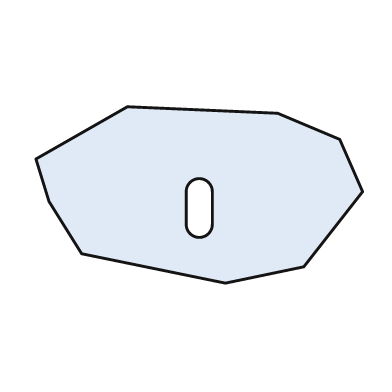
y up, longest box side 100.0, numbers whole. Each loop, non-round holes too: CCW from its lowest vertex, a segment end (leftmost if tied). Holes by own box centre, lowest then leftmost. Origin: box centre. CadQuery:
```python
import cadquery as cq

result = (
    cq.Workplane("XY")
    .moveTo(8.0, -27.0)
    .lineTo(32.0, -22.0)
    .lineTo(50.0, 1.0)
    .lineTo(43.0, 17.0)
    .lineTo(24.0, 25.0)
    .lineTo(-22.0, 27.0)
    .lineTo(-50.0, 11.0)
    .lineTo(-46.0, -2.0)
    .lineTo(-36.0, -18.0)
    .close()
    .moveTo(-4.0, -9.0)
    .threePointArc((0.0, -13.0), (4.0, -9.0))
    .lineTo(4.0, 1.0)
    .threePointArc((0.0, 5.0), (-4.0, 1.0))
    .close()
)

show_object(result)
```